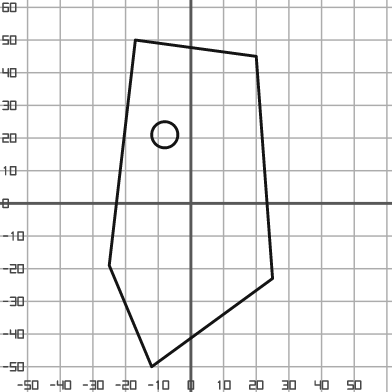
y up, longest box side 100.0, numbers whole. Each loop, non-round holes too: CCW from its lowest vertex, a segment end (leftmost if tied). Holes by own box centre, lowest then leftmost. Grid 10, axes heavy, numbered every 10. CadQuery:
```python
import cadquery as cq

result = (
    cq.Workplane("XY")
    .moveTo(-12.0, -50.0)
    .lineTo(25.0, -23.0)
    .lineTo(20.0, 45.0)
    .lineTo(-17.0, 50.0)
    .lineTo(-25.0, -19.0)
    .close()
    .moveTo(-8.0, 21.0)
    .circle(4.0)
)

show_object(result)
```